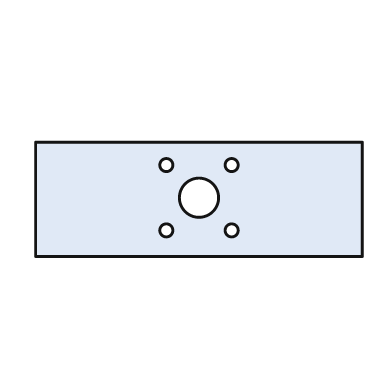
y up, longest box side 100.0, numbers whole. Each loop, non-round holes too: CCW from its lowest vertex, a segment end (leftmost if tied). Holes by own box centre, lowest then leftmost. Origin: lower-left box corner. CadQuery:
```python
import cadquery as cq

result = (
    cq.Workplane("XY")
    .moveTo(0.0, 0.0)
    .lineTo(100.0, 0.0)
    .lineTo(100.0, 35.0)
    .lineTo(0.0, 35.0)
    .close()
    .moveTo(40.0, 8.0)
    .circle(2.0)
    .moveTo(60.0, 8.0)
    .circle(2.0)
    .moveTo(50.0, 18.0)
    .circle(6.0)
    .moveTo(40.0, 28.0)
    .circle(2.0)
    .moveTo(60.0, 28.0)
    .circle(2.0)
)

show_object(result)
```